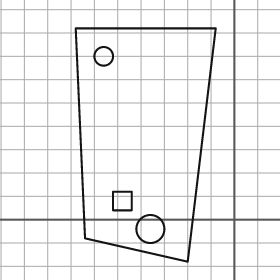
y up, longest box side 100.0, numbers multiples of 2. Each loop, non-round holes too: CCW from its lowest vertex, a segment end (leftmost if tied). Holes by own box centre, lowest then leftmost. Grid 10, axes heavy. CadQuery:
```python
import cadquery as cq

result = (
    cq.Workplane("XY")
    .moveTo(-20.0, -18.0)
    .lineTo(-8.0, 82.0)
    .lineTo(-68.0, 82.0)
    .lineTo(-64.0, -8.0)
    .close()
    .moveTo(-36.0, -4.0)
    .circle(6.0)
    .moveTo(-52.0, 4.0)
    .lineTo(-44.0, 4.0)
    .lineTo(-44.0, 12.0)
    .lineTo(-52.0, 12.0)
    .close()
    .moveTo(-56.0, 70.0)
    .circle(4.0)
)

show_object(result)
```